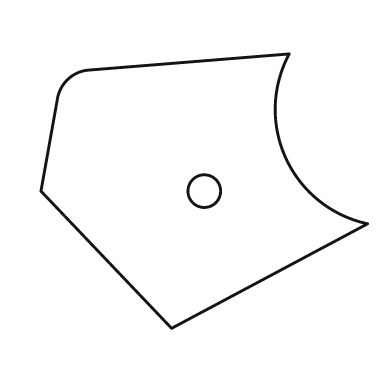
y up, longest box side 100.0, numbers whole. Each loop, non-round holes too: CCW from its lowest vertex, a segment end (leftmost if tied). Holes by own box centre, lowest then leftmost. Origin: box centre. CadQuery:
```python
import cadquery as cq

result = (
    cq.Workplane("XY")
    .moveTo(-10.0, -42.0)
    .lineTo(50.0, -10.0)
    .threePointArc((25.0, 10.0), (26.0, 42.0))
    .lineTo(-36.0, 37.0)
    .threePointArc((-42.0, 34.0), (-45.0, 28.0))
    .lineTo(-50.0, 0.0)
    .close()
    .moveTo(0.0, 0.0)
    .circle(5.0)
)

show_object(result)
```